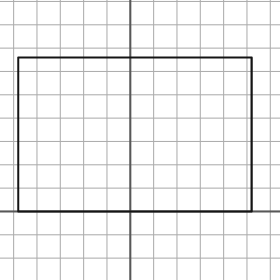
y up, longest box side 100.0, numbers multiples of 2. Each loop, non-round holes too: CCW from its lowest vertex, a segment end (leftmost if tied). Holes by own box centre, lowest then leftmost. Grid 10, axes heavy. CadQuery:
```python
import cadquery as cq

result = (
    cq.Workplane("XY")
    .moveTo(-48.0, 0.0)
    .lineTo(52.0, 0.0)
    .lineTo(52.0, 66.0)
    .lineTo(-48.0, 66.0)
    .close()
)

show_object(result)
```